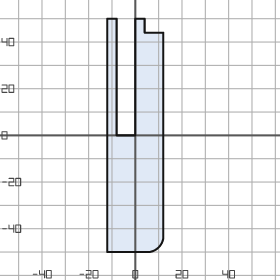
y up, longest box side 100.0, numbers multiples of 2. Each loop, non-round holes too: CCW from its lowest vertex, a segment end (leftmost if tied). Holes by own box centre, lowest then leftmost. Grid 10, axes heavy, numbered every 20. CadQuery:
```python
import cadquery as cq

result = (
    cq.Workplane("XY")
    .moveTo(-12.0, -50.0)
    .lineTo(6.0, -50.0)
    .threePointArc((10.0, -48.0), (12.0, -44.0))
    .lineTo(12.0, 44.0)
    .lineTo(4.0, 44.0)
    .lineTo(4.0, 50.0)
    .lineTo(0.0, 50.0)
    .lineTo(0.0, 0.0)
    .lineTo(-8.0, 0.0)
    .lineTo(-8.0, 50.0)
    .lineTo(-12.0, 50.0)
    .close()
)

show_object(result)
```